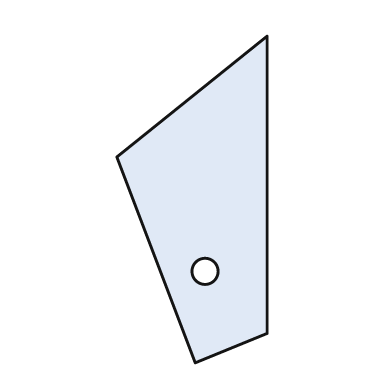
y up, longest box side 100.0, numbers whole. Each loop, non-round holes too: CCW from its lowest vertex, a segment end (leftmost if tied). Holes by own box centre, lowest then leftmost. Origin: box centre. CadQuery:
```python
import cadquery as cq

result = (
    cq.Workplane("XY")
    .moveTo(1.0, -50.0)
    .lineTo(23.0, -41.0)
    .lineTo(23.0, 50.0)
    .lineTo(-23.0, 13.0)
    .close()
    .moveTo(4.0, -22.0)
    .circle(4.0)
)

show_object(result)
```